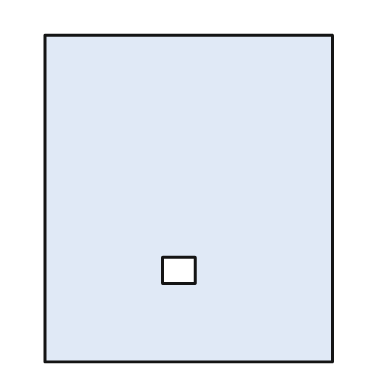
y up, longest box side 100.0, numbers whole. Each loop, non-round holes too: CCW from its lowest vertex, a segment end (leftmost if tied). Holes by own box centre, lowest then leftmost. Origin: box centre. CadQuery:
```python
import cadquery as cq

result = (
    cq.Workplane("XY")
    .moveTo(-44.0, -50.0)
    .lineTo(44.0, -50.0)
    .lineTo(44.0, 50.0)
    .lineTo(-44.0, 50.0)
    .close()
    .moveTo(-8.0, -26.0)
    .lineTo(2.0, -26.0)
    .lineTo(2.0, -18.0)
    .lineTo(-8.0, -18.0)
    .close()
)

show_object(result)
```